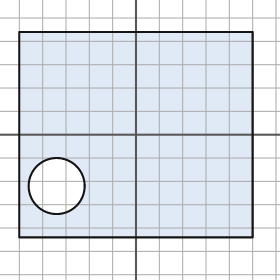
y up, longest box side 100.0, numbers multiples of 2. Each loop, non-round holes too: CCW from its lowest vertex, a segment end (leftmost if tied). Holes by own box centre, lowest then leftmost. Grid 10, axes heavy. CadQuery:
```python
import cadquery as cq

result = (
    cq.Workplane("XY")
    .moveTo(-50.0, -44.0)
    .lineTo(50.0, -44.0)
    .lineTo(50.0, 44.0)
    .lineTo(-50.0, 44.0)
    .close()
    .moveTo(-34.0, -22.0)
    .circle(12.0)
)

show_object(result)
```